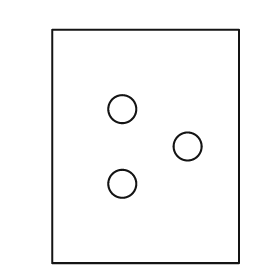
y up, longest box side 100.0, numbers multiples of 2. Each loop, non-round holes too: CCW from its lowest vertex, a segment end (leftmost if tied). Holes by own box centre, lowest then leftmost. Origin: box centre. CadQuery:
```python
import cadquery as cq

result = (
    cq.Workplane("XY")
    .moveTo(-40.0, -50.0)
    .lineTo(40.0, -50.0)
    .lineTo(40.0, 50.0)
    .lineTo(-40.0, 50.0)
    .close()
    .moveTo(-10.0, -16.0)
    .circle(6.0)
    .moveTo(18.0, 0.0)
    .circle(6.0)
    .moveTo(-10.0, 16.0)
    .circle(6.0)
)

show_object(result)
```